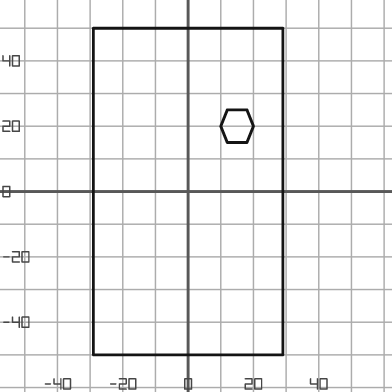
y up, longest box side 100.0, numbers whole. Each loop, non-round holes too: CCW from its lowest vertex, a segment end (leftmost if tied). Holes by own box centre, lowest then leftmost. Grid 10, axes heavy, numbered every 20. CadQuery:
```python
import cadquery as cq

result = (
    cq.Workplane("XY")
    .moveTo(-29.0, -50.0)
    .lineTo(29.0, -50.0)
    .lineTo(29.0, 50.0)
    .lineTo(-29.0, 50.0)
    .close()
    .moveTo(12.0, 15.0)
    .lineTo(18.0, 15.0)
    .lineTo(20.0, 20.0)
    .lineTo(18.0, 25.0)
    .lineTo(12.0, 25.0)
    .lineTo(10.0, 20.0)
    .close()
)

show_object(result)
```